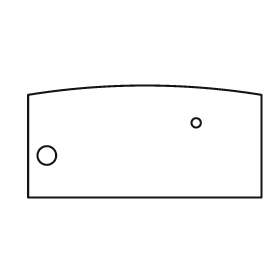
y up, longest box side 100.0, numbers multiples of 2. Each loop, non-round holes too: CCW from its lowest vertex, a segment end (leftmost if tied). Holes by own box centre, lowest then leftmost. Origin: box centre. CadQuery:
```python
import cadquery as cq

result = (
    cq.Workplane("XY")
    .moveTo(-50.0, -24.0)
    .lineTo(50.0, -24.0)
    .lineTo(50.0, 20.0)
    .threePointArc((0.0, 24.0), (-50.0, 20.0))
    .close()
    .moveTo(-42.0, -6.0)
    .circle(4.0)
    .moveTo(22.0, 8.0)
    .circle(2.0)
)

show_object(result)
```